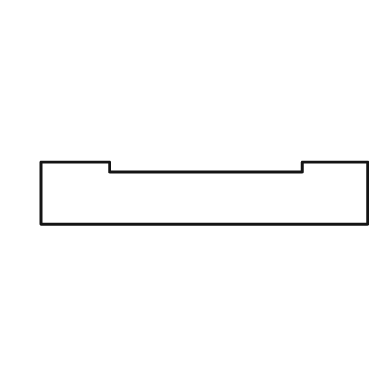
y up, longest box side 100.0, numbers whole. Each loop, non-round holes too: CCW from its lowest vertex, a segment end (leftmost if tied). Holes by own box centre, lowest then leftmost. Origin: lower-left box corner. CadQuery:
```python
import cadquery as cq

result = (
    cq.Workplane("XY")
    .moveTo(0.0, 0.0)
    .lineTo(100.0, 0.0)
    .lineTo(100.0, 19.0)
    .lineTo(80.0, 19.0)
    .lineTo(80.0, 16.0)
    .lineTo(21.0, 16.0)
    .lineTo(21.0, 19.0)
    .lineTo(0.0, 19.0)
    .close()
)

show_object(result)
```